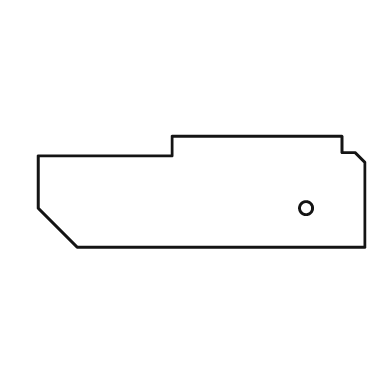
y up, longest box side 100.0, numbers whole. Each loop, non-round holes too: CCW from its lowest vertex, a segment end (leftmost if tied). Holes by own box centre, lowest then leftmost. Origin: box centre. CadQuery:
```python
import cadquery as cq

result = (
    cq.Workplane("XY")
    .moveTo(-38.0, -17.0)
    .lineTo(50.0, -17.0)
    .lineTo(50.0, 9.0)
    .lineTo(47.0, 12.0)
    .lineTo(43.0, 12.0)
    .lineTo(43.0, 17.0)
    .lineTo(-9.0, 17.0)
    .lineTo(-9.0, 11.0)
    .lineTo(-50.0, 11.0)
    .lineTo(-50.0, -5.0)
    .close()
    .moveTo(32.0, -5.0)
    .circle(2.0)
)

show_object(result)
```